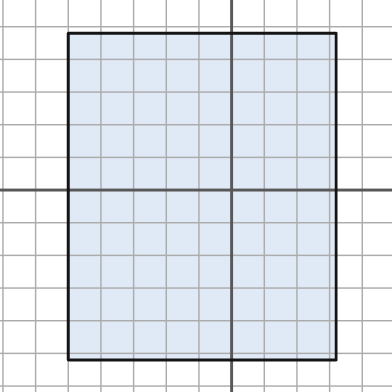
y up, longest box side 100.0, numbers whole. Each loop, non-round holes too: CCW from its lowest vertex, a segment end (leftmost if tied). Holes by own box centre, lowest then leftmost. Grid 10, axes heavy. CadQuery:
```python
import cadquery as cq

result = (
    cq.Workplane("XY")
    .moveTo(-50.0, -52.0)
    .lineTo(32.0, -52.0)
    .lineTo(32.0, 48.0)
    .lineTo(-50.0, 48.0)
    .close()
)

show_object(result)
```